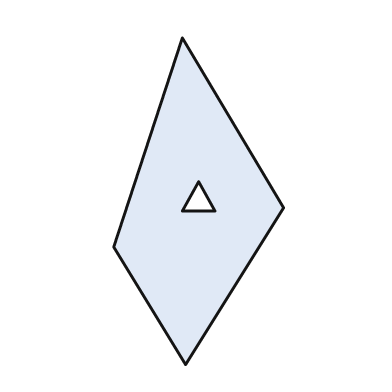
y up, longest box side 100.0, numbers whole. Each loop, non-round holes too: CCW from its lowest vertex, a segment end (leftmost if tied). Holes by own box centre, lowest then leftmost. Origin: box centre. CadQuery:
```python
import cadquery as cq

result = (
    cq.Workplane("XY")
    .moveTo(-4.0, -50.0)
    .lineTo(26.0, -2.0)
    .lineTo(-5.0, 50.0)
    .lineTo(-26.0, -14.0)
    .close()
    .moveTo(-5.0, -3.0)
    .lineTo(5.0, -3.0)
    .lineTo(0.0, 6.0)
    .close()
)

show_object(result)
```